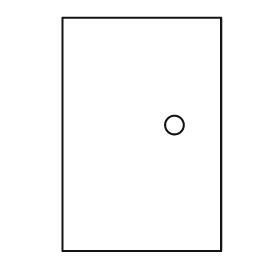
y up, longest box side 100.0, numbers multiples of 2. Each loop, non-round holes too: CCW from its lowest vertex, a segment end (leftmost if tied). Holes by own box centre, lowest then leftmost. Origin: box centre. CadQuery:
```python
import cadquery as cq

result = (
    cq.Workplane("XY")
    .moveTo(-34.0, -50.0)
    .lineTo(34.0, -50.0)
    .lineTo(34.0, 50.0)
    .lineTo(-34.0, 50.0)
    .close()
    .moveTo(14.0, 4.0)
    .circle(4.0)
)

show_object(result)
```